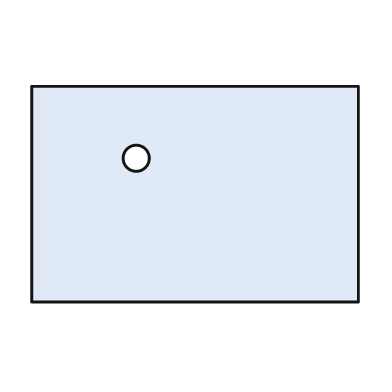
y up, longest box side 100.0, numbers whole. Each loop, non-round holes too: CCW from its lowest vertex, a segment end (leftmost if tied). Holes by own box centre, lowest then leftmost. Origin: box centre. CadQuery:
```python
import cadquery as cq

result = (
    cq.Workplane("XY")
    .moveTo(-50.0, -33.0)
    .lineTo(50.0, -33.0)
    .lineTo(50.0, 33.0)
    .lineTo(-50.0, 33.0)
    .close()
    .moveTo(-18.0, 11.0)
    .circle(4.0)
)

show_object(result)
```